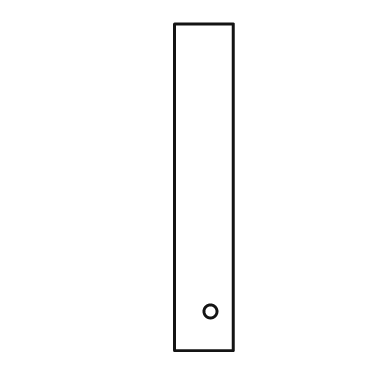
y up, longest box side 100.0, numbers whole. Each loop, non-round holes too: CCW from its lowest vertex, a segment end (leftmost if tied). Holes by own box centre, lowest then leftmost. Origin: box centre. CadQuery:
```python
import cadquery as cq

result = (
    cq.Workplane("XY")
    .moveTo(-9.0, -50.0)
    .lineTo(9.0, -50.0)
    .lineTo(9.0, 50.0)
    .lineTo(-9.0, 50.0)
    .close()
    .moveTo(2.0, -38.0)
    .circle(2.0)
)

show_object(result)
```